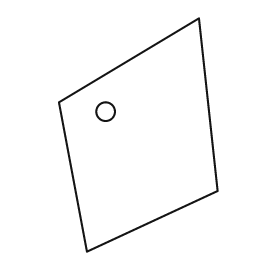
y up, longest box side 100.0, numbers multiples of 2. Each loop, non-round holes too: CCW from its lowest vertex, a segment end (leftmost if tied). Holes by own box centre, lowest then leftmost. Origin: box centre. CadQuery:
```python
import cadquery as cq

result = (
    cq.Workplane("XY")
    .moveTo(-22.0, -50.0)
    .lineTo(34.0, -24.0)
    .lineTo(26.0, 50.0)
    .lineTo(-34.0, 14.0)
    .close()
    .moveTo(-14.0, 10.0)
    .circle(4.0)
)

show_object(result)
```